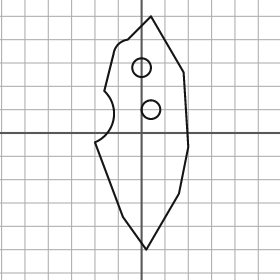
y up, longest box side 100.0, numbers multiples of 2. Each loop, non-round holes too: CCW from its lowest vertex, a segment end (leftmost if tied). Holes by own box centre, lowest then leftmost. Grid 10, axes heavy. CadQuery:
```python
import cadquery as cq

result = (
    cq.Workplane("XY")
    .moveTo(2.0, -50.0)
    .lineTo(16.0, -26.0)
    .lineTo(20.0, -6.0)
    .lineTo(18.0, 26.0)
    .lineTo(4.0, 50.0)
    .lineTo(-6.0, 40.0)
    .threePointArc((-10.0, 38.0), (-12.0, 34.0))
    .lineTo(-16.0, 18.0)
    .threePointArc((-12.0, 6.0), (-20.0, -4.0))
    .lineTo(-8.0, -36.0)
    .close()
    .moveTo(4.0, 10.0)
    .circle(4.0)
    .moveTo(0.0, 28.0)
    .circle(4.0)
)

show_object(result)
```